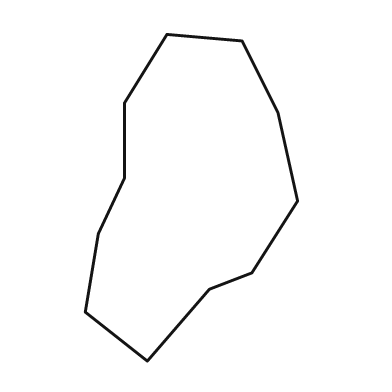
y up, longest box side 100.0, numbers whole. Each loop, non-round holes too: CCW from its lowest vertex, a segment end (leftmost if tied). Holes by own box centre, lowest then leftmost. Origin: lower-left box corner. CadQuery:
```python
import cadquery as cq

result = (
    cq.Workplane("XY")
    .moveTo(19.0, 0.0)
    .lineTo(38.0, 22.0)
    .lineTo(51.0, 27.0)
    .lineTo(65.0, 49.0)
    .lineTo(59.0, 76.0)
    .lineTo(48.0, 98.0)
    .lineTo(25.0, 100.0)
    .lineTo(12.0, 79.0)
    .lineTo(12.0, 56.0)
    .lineTo(4.0, 39.0)
    .lineTo(0.0, 15.0)
    .close()
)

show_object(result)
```